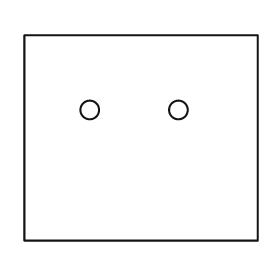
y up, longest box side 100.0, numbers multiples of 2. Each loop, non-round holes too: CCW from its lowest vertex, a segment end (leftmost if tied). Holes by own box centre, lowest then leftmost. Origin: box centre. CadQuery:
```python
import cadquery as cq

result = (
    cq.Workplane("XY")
    .moveTo(-50.0, -44.0)
    .lineTo(50.0, -44.0)
    .lineTo(50.0, 44.0)
    .lineTo(-50.0, 44.0)
    .close()
    .moveTo(-22.0, 12.0)
    .circle(4.0)
    .moveTo(16.0, 12.0)
    .circle(4.0)
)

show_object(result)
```